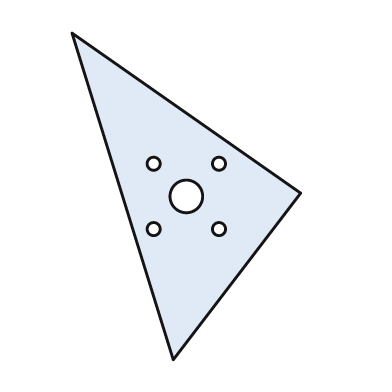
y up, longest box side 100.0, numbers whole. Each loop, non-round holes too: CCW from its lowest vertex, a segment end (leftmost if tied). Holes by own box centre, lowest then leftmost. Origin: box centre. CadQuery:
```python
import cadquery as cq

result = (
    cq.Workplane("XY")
    .moveTo(-4.0, -50.0)
    .lineTo(35.0, 1.0)
    .lineTo(-35.0, 50.0)
    .close()
    .moveTo(-10.0, -10.0)
    .circle(2.0)
    .moveTo(10.0, -10.0)
    .circle(2.0)
    .moveTo(0.0, 0.0)
    .circle(5.0)
    .moveTo(-10.0, 10.0)
    .circle(2.0)
    .moveTo(10.0, 10.0)
    .circle(2.0)
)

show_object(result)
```